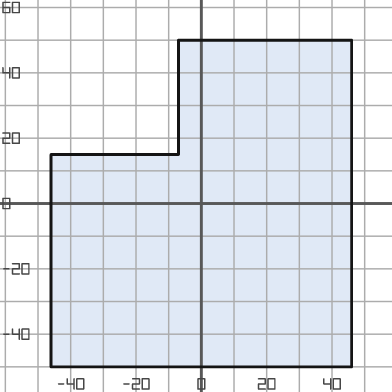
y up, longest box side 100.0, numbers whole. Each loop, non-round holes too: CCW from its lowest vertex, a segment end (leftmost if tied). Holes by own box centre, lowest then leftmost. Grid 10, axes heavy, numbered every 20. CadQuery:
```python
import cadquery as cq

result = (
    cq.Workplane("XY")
    .moveTo(-46.0, -50.0)
    .lineTo(46.0, -50.0)
    .lineTo(46.0, 50.0)
    .lineTo(-7.0, 50.0)
    .lineTo(-7.0, 15.0)
    .lineTo(-46.0, 15.0)
    .close()
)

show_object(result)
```